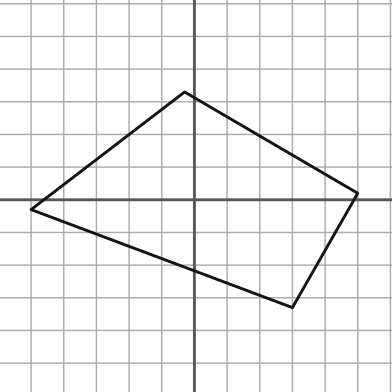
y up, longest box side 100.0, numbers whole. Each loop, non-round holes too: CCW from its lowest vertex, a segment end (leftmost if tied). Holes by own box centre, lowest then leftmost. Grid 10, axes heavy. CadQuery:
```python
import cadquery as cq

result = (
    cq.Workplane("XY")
    .moveTo(30.0, -33.0)
    .lineTo(50.0, 2.0)
    .lineTo(-3.0, 33.0)
    .lineTo(-50.0, -3.0)
    .close()
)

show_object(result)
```